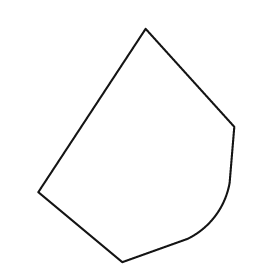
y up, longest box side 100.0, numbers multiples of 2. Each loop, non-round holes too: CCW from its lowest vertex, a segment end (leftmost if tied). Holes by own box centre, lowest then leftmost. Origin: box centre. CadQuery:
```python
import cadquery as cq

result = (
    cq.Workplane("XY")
    .moveTo(-6.0, -50.0)
    .lineTo(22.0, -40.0)
    .threePointArc((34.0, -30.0), (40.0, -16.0))
    .lineTo(42.0, 8.0)
    .lineTo(4.0, 50.0)
    .lineTo(-42.0, -20.0)
    .close()
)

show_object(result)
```